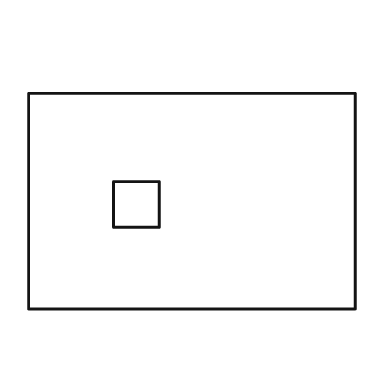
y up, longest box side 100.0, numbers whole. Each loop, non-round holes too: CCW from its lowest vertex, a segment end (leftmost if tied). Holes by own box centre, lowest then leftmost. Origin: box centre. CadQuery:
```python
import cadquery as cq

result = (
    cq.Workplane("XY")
    .moveTo(-50.0, -33.0)
    .lineTo(50.0, -33.0)
    .lineTo(50.0, 33.0)
    .lineTo(-50.0, 33.0)
    .close()
    .moveTo(-24.0, -8.0)
    .lineTo(-10.0, -8.0)
    .lineTo(-10.0, 6.0)
    .lineTo(-24.0, 6.0)
    .close()
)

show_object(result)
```